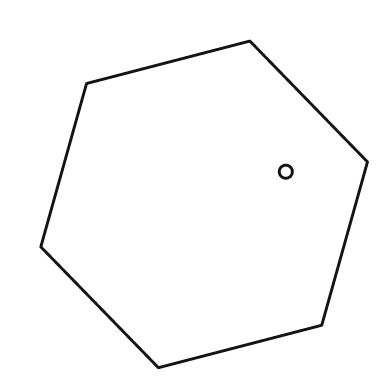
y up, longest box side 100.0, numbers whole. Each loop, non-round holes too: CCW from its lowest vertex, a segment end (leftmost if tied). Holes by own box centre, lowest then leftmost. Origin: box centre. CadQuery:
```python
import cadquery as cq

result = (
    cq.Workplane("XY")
    .moveTo(-14.0, -50.0)
    .lineTo(36.0, -37.0)
    .lineTo(50.0, 13.0)
    .lineTo(14.0, 50.0)
    .lineTo(-36.0, 37.0)
    .lineTo(-50.0, -13.0)
    .close()
    .moveTo(25.0, 10.0)
    .circle(2.0)
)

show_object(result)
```